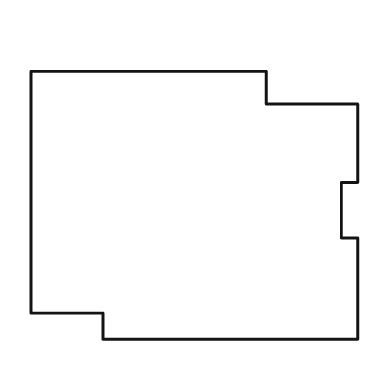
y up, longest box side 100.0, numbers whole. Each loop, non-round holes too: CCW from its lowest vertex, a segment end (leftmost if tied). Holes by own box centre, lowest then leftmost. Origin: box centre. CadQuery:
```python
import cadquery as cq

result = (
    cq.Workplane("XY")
    .moveTo(-28.0, -41.0)
    .lineTo(50.0, -41.0)
    .lineTo(50.0, -10.0)
    .lineTo(45.0, -10.0)
    .lineTo(45.0, 7.0)
    .lineTo(50.0, 7.0)
    .lineTo(50.0, 31.0)
    .lineTo(22.0, 31.0)
    .lineTo(22.0, 41.0)
    .lineTo(-50.0, 41.0)
    .lineTo(-50.0, -33.0)
    .lineTo(-28.0, -33.0)
    .close()
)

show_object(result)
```